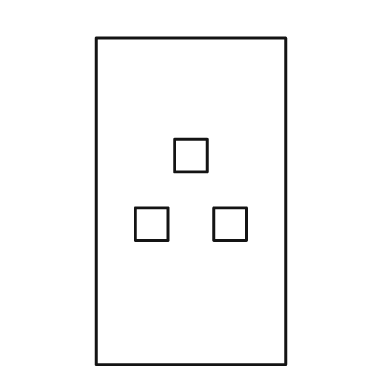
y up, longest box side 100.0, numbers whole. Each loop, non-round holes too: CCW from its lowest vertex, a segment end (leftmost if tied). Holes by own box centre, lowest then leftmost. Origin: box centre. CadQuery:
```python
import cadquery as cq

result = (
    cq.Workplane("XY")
    .moveTo(-29.0, -50.0)
    .lineTo(29.0, -50.0)
    .lineTo(29.0, 50.0)
    .lineTo(-29.0, 50.0)
    .close()
    .moveTo(-17.0, -12.0)
    .lineTo(-7.0, -12.0)
    .lineTo(-7.0, -2.0)
    .lineTo(-17.0, -2.0)
    .close()
    .moveTo(7.0, -12.0)
    .lineTo(17.0, -12.0)
    .lineTo(17.0, -2.0)
    .lineTo(7.0, -2.0)
    .close()
    .moveTo(-5.0, 9.0)
    .lineTo(5.0, 9.0)
    .lineTo(5.0, 19.0)
    .lineTo(-5.0, 19.0)
    .close()
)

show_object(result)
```